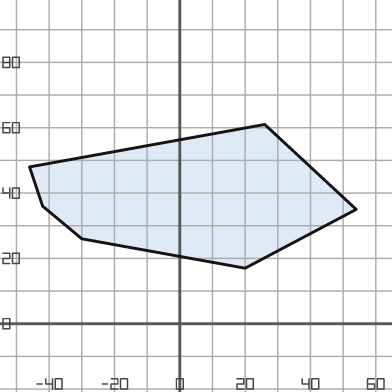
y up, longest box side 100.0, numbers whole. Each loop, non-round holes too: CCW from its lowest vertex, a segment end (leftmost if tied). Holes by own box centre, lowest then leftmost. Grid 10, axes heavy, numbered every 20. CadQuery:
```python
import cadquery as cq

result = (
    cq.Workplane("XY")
    .moveTo(20.0, 17.0)
    .lineTo(54.0, 35.0)
    .lineTo(26.0, 61.0)
    .lineTo(-46.0, 48.0)
    .lineTo(-42.0, 36.0)
    .lineTo(-30.0, 26.0)
    .close()
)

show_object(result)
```